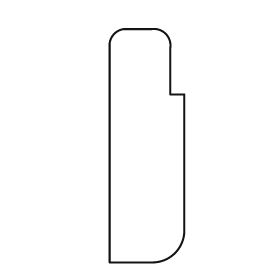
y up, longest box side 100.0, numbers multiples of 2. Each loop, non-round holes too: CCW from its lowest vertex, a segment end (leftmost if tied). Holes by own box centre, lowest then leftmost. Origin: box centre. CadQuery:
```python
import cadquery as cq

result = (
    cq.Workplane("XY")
    .moveTo(-16.0, -50.0)
    .lineTo(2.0, -50.0)
    .threePointArc((12.0, -46.0), (16.0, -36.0))
    .lineTo(16.0, 22.0)
    .lineTo(10.0, 22.0)
    .lineTo(10.0, 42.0)
    .threePointArc((8.0, 48.0), (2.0, 50.0))
    .lineTo(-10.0, 50.0)
    .threePointArc((-14.0, 48.0), (-16.0, 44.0))
    .close()
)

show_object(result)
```